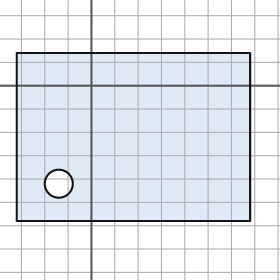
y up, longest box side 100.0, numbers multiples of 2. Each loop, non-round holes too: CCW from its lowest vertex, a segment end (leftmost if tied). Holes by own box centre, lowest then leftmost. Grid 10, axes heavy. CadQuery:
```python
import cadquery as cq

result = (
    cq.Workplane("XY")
    .moveTo(-32.0, -58.0)
    .lineTo(68.0, -58.0)
    .lineTo(68.0, 14.0)
    .lineTo(-32.0, 14.0)
    .close()
    .moveTo(-14.0, -42.0)
    .circle(6.0)
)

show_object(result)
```